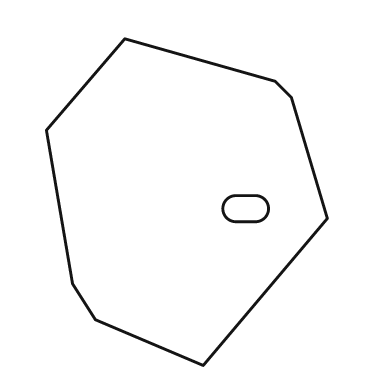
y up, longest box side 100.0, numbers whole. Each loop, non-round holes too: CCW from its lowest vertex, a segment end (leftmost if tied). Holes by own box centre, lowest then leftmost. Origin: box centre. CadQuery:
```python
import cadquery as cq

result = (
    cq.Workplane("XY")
    .moveTo(5.0, -50.0)
    .lineTo(43.0, -5.0)
    .lineTo(32.0, 32.0)
    .lineTo(27.0, 37.0)
    .lineTo(-19.0, 50.0)
    .lineTo(-43.0, 22.0)
    .lineTo(-35.0, -25.0)
    .lineTo(-28.0, -36.0)
    .close()
    .moveTo(15.0, -6.0)
    .lineTo(21.0, -6.0)
    .threePointArc((25.0, -2.0), (21.0, 2.0))
    .lineTo(15.0, 2.0)
    .threePointArc((11.0, -2.0), (15.0, -6.0))
    .close()
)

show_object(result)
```